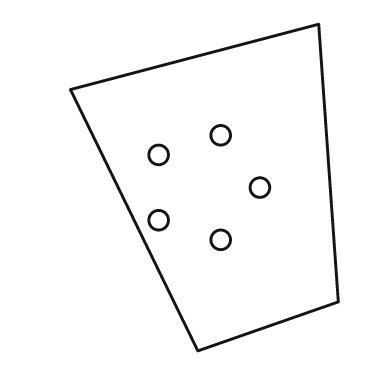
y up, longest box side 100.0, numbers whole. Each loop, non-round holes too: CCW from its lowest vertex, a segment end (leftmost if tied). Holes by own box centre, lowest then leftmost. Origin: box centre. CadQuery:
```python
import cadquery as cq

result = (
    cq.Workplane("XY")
    .moveTo(-2.0, -50.0)
    .lineTo(41.0, -35.0)
    .lineTo(35.0, 50.0)
    .lineTo(-41.0, 30.0)
    .close()
    .moveTo(5.0, -16.0)
    .circle(3.0)
    .moveTo(-14.0, -10.0)
    .circle(3.0)
    .moveTo(17.0, 0.0)
    .circle(3.0)
    .moveTo(-14.0, 10.0)
    .circle(3.0)
    .moveTo(5.0, 16.0)
    .circle(3.0)
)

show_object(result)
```